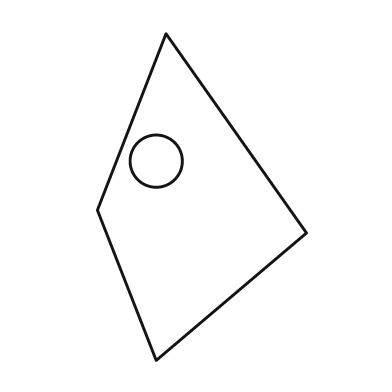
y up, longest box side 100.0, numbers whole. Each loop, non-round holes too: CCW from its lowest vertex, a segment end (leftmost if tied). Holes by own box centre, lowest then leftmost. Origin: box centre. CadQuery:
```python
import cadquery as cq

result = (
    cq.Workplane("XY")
    .moveTo(-14.0, -50.0)
    .lineTo(32.0, -11.0)
    .lineTo(-11.0, 50.0)
    .lineTo(-32.0, -4.0)
    .close()
    .moveTo(-14.0, 11.0)
    .circle(8.0)
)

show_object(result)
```